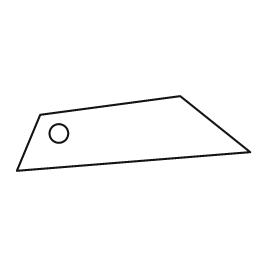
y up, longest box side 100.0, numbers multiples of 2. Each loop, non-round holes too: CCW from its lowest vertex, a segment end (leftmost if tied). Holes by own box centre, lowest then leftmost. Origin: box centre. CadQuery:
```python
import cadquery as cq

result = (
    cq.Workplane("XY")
    .moveTo(-50.0, -16.0)
    .lineTo(50.0, -8.0)
    .lineTo(20.0, 16.0)
    .lineTo(-40.0, 8.0)
    .close()
    .moveTo(-32.0, 0.0)
    .circle(4.0)
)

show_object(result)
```